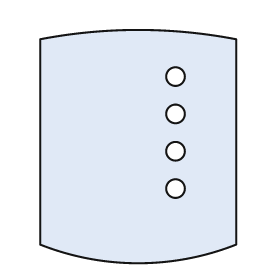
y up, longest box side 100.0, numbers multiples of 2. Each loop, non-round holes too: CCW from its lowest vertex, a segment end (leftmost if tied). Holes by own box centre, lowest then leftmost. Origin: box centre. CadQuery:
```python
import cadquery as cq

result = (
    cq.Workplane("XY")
    .moveTo(-42.0, -42.0)
    .threePointArc((0.0, -50.0), (42.0, -42.0))
    .lineTo(42.0, 46.0)
    .threePointArc((0.0, 50.0), (-42.0, 46.0))
    .close()
    .moveTo(16.0, -18.0)
    .circle(4.0)
    .moveTo(16.0, -2.0)
    .circle(4.0)
    .moveTo(16.0, 14.0)
    .circle(4.0)
    .moveTo(16.0, 30.0)
    .circle(4.0)
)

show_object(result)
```